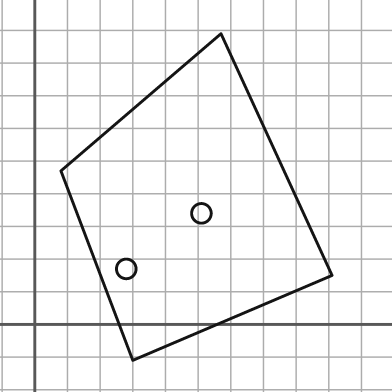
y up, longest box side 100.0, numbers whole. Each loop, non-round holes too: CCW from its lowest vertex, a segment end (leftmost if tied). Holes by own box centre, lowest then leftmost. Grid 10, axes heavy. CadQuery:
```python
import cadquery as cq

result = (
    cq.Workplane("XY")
    .moveTo(30.0, -11.0)
    .lineTo(91.0, 15.0)
    .lineTo(57.0, 89.0)
    .lineTo(8.0, 47.0)
    .close()
    .moveTo(28.0, 17.0)
    .circle(3.0)
    .moveTo(51.0, 34.0)
    .circle(3.0)
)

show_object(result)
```